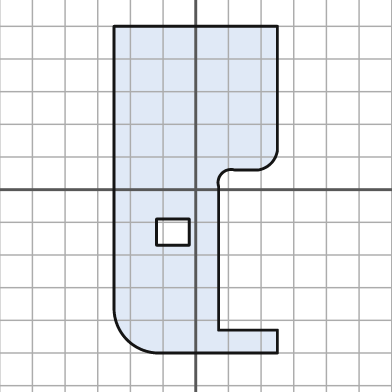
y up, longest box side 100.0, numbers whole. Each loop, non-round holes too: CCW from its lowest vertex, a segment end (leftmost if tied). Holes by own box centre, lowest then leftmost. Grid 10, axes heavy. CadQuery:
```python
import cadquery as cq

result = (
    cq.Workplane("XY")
    .moveTo(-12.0, -50.0)
    .lineTo(25.0, -50.0)
    .lineTo(25.0, -43.0)
    .lineTo(7.0, -43.0)
    .lineTo(7.0, 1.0)
    .threePointArc((8.0, 5.0), (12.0, 6.0))
    .lineTo(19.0, 6.0)
    .threePointArc((23.0, 8.0), (25.0, 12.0))
    .lineTo(25.0, 50.0)
    .lineTo(-25.0, 50.0)
    .lineTo(-25.0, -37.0)
    .threePointArc((-21.0, -46.0), (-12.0, -50.0))
    .close()
    .moveTo(-12.0, -17.0)
    .lineTo(-2.0, -17.0)
    .lineTo(-2.0, -9.0)
    .lineTo(-12.0, -9.0)
    .close()
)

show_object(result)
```